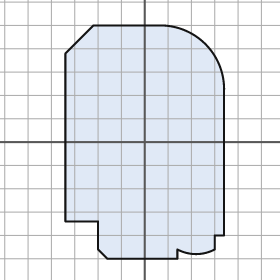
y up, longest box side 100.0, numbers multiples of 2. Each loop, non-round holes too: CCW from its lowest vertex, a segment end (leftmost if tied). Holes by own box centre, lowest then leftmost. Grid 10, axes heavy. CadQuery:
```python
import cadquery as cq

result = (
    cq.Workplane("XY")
    .moveTo(-16.0, -50.0)
    .lineTo(14.0, -50.0)
    .lineTo(14.0, -46.0)
    .threePointArc((22.0, -48.0), (30.0, -46.0))
    .lineTo(30.0, -40.0)
    .lineTo(34.0, -40.0)
    .lineTo(34.0, 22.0)
    .threePointArc((26.0, 42.0), (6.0, 50.0))
    .lineTo(-22.0, 50.0)
    .lineTo(-34.0, 38.0)
    .lineTo(-34.0, -34.0)
    .lineTo(-20.0, -34.0)
    .lineTo(-20.0, -46.0)
    .close()
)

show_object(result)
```